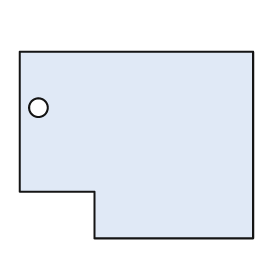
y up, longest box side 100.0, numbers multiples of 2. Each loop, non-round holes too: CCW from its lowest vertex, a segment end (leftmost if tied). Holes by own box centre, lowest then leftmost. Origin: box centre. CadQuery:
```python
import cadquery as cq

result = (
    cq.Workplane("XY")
    .moveTo(-18.0, -40.0)
    .lineTo(50.0, -40.0)
    .lineTo(50.0, 40.0)
    .lineTo(-50.0, 40.0)
    .lineTo(-50.0, -20.0)
    .lineTo(-18.0, -20.0)
    .close()
    .moveTo(-42.0, 16.0)
    .circle(4.0)
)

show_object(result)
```